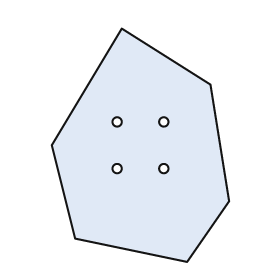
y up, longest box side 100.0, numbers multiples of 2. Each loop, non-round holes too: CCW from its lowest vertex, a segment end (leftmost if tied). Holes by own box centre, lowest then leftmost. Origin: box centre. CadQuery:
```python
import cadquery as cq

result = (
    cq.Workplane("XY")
    .moveTo(20.0, -50.0)
    .lineTo(38.0, -24.0)
    .lineTo(30.0, 26.0)
    .lineTo(-8.0, 50.0)
    .lineTo(-38.0, 0.0)
    .lineTo(-28.0, -40.0)
    .close()
    .moveTo(-10.0, -10.0)
    .circle(2.0)
    .moveTo(10.0, -10.0)
    .circle(2.0)
    .moveTo(-10.0, 10.0)
    .circle(2.0)
    .moveTo(10.0, 10.0)
    .circle(2.0)
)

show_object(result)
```